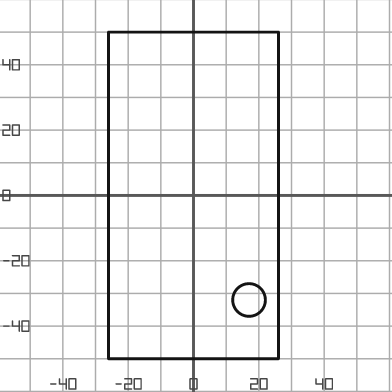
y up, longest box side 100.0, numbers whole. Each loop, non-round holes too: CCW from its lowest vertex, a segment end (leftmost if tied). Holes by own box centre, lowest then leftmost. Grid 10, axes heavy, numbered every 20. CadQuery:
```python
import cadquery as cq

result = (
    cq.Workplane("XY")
    .moveTo(-26.0, -50.0)
    .lineTo(26.0, -50.0)
    .lineTo(26.0, 50.0)
    .lineTo(-26.0, 50.0)
    .close()
    .moveTo(17.0, -32.0)
    .circle(5.0)
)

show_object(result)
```